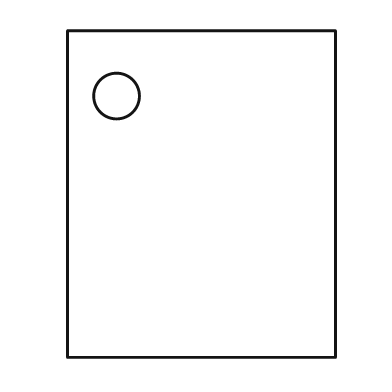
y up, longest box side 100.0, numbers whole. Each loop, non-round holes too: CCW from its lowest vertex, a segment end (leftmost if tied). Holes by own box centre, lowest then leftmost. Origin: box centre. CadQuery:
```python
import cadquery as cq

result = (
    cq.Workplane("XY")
    .moveTo(-41.0, -50.0)
    .lineTo(41.0, -50.0)
    .lineTo(41.0, 50.0)
    .lineTo(-41.0, 50.0)
    .close()
    .moveTo(-26.0, 30.0)
    .circle(7.0)
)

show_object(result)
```